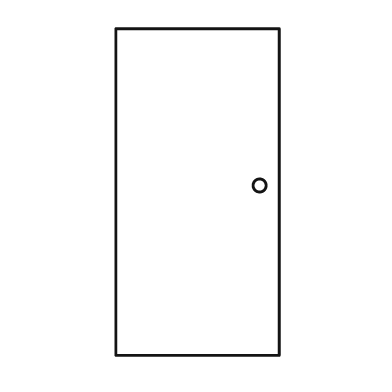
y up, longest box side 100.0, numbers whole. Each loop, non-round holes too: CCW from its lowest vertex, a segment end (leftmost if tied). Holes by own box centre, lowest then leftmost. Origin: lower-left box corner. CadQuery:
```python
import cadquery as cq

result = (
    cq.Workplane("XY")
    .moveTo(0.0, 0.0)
    .lineTo(50.0, 0.0)
    .lineTo(50.0, 100.0)
    .lineTo(0.0, 100.0)
    .close()
    .moveTo(44.0, 52.0)
    .circle(2.0)
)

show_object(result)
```